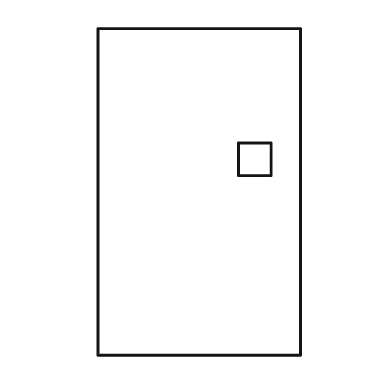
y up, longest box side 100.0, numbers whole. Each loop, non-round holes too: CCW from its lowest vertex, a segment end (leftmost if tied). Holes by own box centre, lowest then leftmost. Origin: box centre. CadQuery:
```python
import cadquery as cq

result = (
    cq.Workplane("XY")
    .moveTo(-31.0, -50.0)
    .lineTo(31.0, -50.0)
    .lineTo(31.0, 50.0)
    .lineTo(-31.0, 50.0)
    .close()
    .moveTo(12.0, 5.0)
    .lineTo(22.0, 5.0)
    .lineTo(22.0, 15.0)
    .lineTo(12.0, 15.0)
    .close()
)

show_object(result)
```